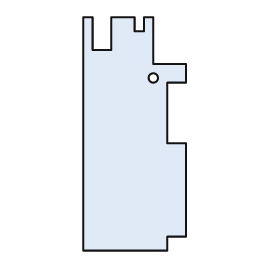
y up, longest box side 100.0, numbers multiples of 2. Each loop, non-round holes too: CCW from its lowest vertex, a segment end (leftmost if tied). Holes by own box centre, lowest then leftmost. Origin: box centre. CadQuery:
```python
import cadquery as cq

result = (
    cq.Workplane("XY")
    .moveTo(-22.0, -50.0)
    .lineTo(14.0, -50.0)
    .lineTo(14.0, -44.0)
    .lineTo(22.0, -44.0)
    .lineTo(22.0, -4.0)
    .lineTo(14.0, -4.0)
    .lineTo(14.0, 22.0)
    .lineTo(22.0, 22.0)
    .lineTo(22.0, 30.0)
    .lineTo(8.0, 30.0)
    .lineTo(8.0, 50.0)
    .lineTo(4.0, 50.0)
    .lineTo(4.0, 44.0)
    .lineTo(0.0, 44.0)
    .lineTo(0.0, 50.0)
    .lineTo(-10.0, 50.0)
    .lineTo(-10.0, 36.0)
    .lineTo(-18.0, 36.0)
    .lineTo(-18.0, 50.0)
    .lineTo(-22.0, 50.0)
    .close()
    .moveTo(8.0, 24.0)
    .circle(2.0)
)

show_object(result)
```